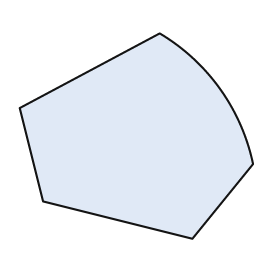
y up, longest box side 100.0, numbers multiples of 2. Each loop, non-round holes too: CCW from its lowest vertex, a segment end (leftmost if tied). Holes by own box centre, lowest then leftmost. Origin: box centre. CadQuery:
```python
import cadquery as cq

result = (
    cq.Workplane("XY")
    .moveTo(24.0, -44.0)
    .lineTo(50.0, -12.0)
    .threePointArc((36.0, 20.0), (10.0, 44.0))
    .lineTo(-50.0, 12.0)
    .lineTo(-40.0, -28.0)
    .close()
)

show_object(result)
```